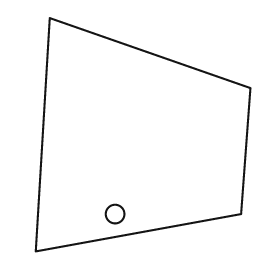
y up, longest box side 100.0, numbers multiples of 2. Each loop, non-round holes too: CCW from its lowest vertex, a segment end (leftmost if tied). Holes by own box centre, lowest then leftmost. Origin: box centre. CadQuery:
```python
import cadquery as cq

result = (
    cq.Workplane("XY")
    .moveTo(-46.0, -50.0)
    .lineTo(42.0, -34.0)
    .lineTo(46.0, 20.0)
    .lineTo(-40.0, 50.0)
    .close()
    .moveTo(-12.0, -34.0)
    .circle(4.0)
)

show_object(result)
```